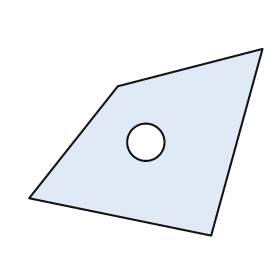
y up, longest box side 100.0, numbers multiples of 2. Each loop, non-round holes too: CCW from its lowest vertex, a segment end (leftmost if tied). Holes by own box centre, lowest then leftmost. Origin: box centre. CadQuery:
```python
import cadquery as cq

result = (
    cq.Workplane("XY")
    .moveTo(28.0, -40.0)
    .lineTo(50.0, 40.0)
    .lineTo(-12.0, 24.0)
    .lineTo(-50.0, -24.0)
    .close()
    .moveTo(0.0, 0.0)
    .circle(8.0)
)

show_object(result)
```